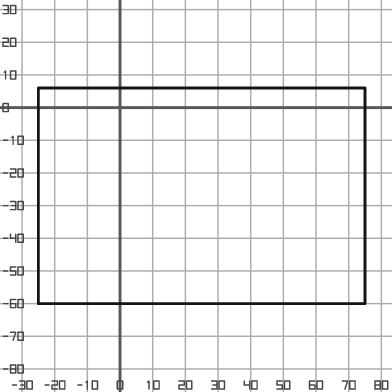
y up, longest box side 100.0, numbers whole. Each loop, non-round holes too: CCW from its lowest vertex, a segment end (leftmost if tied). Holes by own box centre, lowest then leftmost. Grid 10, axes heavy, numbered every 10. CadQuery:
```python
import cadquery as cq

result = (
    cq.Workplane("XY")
    .moveTo(-25.0, -60.0)
    .lineTo(75.0, -60.0)
    .lineTo(75.0, 6.0)
    .lineTo(-25.0, 6.0)
    .close()
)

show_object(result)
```